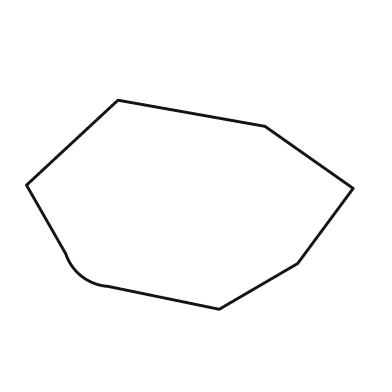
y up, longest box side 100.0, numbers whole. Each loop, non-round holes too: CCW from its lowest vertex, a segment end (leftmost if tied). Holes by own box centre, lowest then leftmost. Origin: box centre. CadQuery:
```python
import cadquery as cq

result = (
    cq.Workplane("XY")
    .moveTo(9.0, -32.0)
    .lineTo(33.0, -18.0)
    .lineTo(50.0, 5.0)
    .lineTo(23.0, 24.0)
    .lineTo(-22.0, 32.0)
    .lineTo(-50.0, 6.0)
    .lineTo(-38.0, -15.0)
    .threePointArc((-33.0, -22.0), (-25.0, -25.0))
    .close()
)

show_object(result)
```